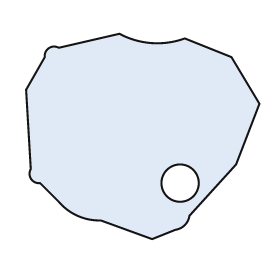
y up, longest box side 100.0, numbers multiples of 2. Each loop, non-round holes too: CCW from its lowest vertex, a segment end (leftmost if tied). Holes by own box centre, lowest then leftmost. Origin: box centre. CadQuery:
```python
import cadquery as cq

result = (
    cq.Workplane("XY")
    .moveTo(4.0, -44.0)
    .lineTo(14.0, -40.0)
    .threePointArc((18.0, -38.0), (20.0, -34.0))
    .lineTo(40.0, -12.0)
    .lineTo(50.0, 14.0)
    .lineTo(38.0, 34.0)
    .lineTo(18.0, 42.0)
    .threePointArc((4.0, 40.0), (-10.0, 44.0))
    .lineTo(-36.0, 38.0)
    .threePointArc((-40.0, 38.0), (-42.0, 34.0))
    .lineTo(-50.0, 20.0)
    .lineTo(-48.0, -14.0)
    .threePointArc((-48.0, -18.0), (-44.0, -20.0))
    .lineTo(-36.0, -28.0)
    .threePointArc((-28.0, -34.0), (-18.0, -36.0))
    .close()
    .moveTo(16.0, -20.0)
    .circle(8.0)
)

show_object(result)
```